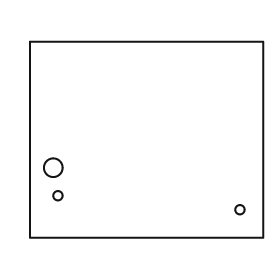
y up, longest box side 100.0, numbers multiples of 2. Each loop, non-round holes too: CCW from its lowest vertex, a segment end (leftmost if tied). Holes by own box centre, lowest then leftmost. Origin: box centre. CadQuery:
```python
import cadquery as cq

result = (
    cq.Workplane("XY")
    .moveTo(-50.0, -42.0)
    .lineTo(50.0, -42.0)
    .lineTo(50.0, 42.0)
    .lineTo(-50.0, 42.0)
    .close()
    .moveTo(40.0, -30.0)
    .circle(2.0)
    .moveTo(-38.0, -24.0)
    .circle(2.0)
    .moveTo(-40.0, -12.0)
    .circle(4.0)
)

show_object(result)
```